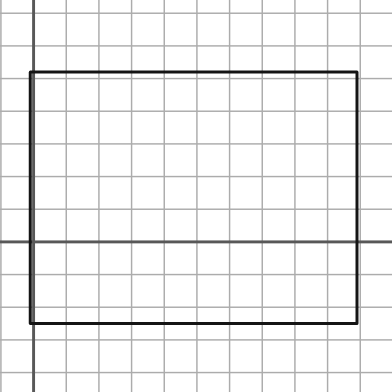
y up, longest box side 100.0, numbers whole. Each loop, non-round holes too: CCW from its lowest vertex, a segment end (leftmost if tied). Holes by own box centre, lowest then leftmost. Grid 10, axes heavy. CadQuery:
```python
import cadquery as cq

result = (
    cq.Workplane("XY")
    .moveTo(-1.0, -25.0)
    .lineTo(99.0, -25.0)
    .lineTo(99.0, 52.0)
    .lineTo(-1.0, 52.0)
    .close()
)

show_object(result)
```